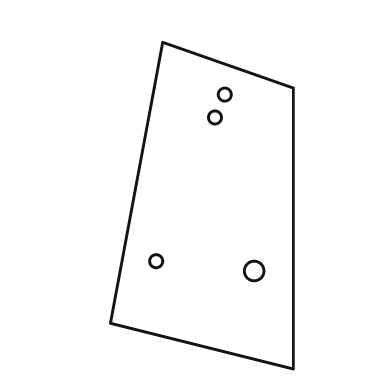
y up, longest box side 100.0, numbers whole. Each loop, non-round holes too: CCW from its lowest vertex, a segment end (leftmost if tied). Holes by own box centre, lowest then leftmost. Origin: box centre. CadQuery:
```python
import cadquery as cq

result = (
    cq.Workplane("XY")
    .moveTo(28.0, -50.0)
    .lineTo(28.0, 36.0)
    .lineTo(-12.0, 50.0)
    .lineTo(-28.0, -36.0)
    .close()
    .moveTo(16.0, -20.0)
    .circle(3.0)
    .moveTo(-14.0, -17.0)
    .circle(2.0)
    .moveTo(4.0, 27.0)
    .circle(2.0)
    .moveTo(7.0, 34.0)
    .circle(2.0)
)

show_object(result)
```